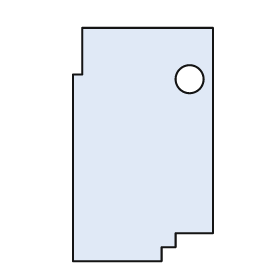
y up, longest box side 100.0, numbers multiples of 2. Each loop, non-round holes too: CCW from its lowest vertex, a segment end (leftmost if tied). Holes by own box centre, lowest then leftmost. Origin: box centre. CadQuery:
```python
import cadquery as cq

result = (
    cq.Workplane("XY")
    .moveTo(-30.0, -50.0)
    .lineTo(8.0, -50.0)
    .lineTo(8.0, -44.0)
    .lineTo(14.0, -44.0)
    .lineTo(14.0, -38.0)
    .lineTo(30.0, -38.0)
    .lineTo(30.0, 50.0)
    .lineTo(-26.0, 50.0)
    .lineTo(-26.0, 30.0)
    .lineTo(-30.0, 30.0)
    .close()
    .moveTo(20.0, 28.0)
    .circle(6.0)
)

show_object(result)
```